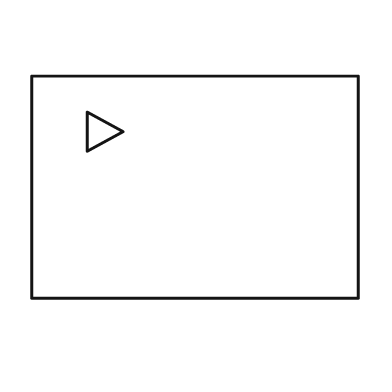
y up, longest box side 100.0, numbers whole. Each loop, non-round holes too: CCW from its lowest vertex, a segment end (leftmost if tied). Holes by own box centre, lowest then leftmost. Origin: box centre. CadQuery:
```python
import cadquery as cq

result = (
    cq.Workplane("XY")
    .moveTo(-50.0, -34.0)
    .lineTo(50.0, -34.0)
    .lineTo(50.0, 34.0)
    .lineTo(-50.0, 34.0)
    .close()
    .moveTo(-33.0, 11.0)
    .lineTo(-22.0, 17.0)
    .lineTo(-33.0, 23.0)
    .close()
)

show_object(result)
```